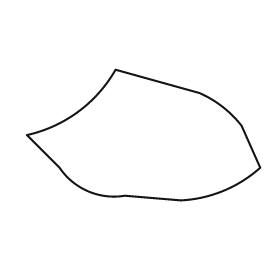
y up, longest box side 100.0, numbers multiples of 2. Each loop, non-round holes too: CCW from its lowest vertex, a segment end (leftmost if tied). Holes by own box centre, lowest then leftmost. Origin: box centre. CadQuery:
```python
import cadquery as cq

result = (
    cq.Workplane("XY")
    .moveTo(16.0, -28.0)
    .threePointArc((34.0, -24.0), (50.0, -14.0))
    .lineTo(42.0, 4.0)
    .threePointArc((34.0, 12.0), (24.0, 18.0))
    .lineTo(-12.0, 28.0)
    .threePointArc((-28.0, 10.0), (-50.0, 0.0))
    .lineTo(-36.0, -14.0)
    .threePointArc((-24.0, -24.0), (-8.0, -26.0))
    .close()
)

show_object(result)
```